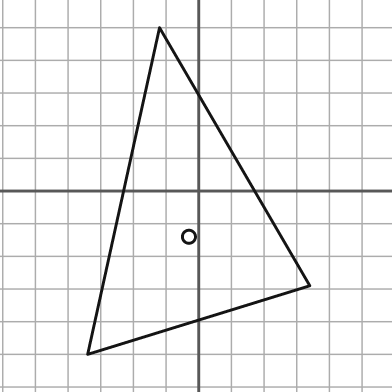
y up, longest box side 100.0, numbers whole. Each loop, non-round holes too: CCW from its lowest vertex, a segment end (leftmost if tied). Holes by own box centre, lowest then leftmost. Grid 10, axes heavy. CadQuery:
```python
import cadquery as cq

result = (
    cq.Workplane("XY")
    .moveTo(-34.0, -50.0)
    .lineTo(34.0, -29.0)
    .lineTo(-12.0, 50.0)
    .close()
    .moveTo(-3.0, -14.0)
    .circle(2.0)
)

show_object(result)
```